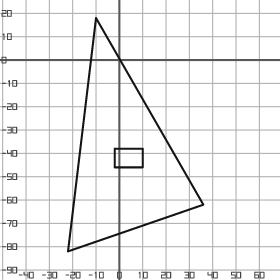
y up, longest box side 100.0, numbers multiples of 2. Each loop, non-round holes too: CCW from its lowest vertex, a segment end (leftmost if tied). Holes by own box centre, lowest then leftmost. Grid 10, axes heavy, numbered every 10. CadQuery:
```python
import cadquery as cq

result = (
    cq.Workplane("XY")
    .moveTo(-22.0, -82.0)
    .lineTo(36.0, -62.0)
    .lineTo(-10.0, 18.0)
    .close()
    .moveTo(-2.0, -46.0)
    .lineTo(10.0, -46.0)
    .lineTo(10.0, -38.0)
    .lineTo(-2.0, -38.0)
    .close()
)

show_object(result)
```